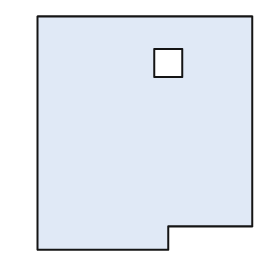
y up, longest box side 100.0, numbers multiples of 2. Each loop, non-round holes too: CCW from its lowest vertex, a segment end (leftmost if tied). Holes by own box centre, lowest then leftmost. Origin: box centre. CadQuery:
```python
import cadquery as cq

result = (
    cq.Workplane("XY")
    .moveTo(-46.0, -50.0)
    .lineTo(10.0, -50.0)
    .lineTo(10.0, -40.0)
    .lineTo(46.0, -40.0)
    .lineTo(46.0, 50.0)
    .lineTo(-46.0, 50.0)
    .close()
    .moveTo(4.0, 24.0)
    .lineTo(16.0, 24.0)
    .lineTo(16.0, 36.0)
    .lineTo(4.0, 36.0)
    .close()
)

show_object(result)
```